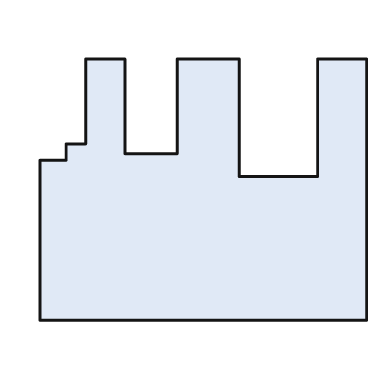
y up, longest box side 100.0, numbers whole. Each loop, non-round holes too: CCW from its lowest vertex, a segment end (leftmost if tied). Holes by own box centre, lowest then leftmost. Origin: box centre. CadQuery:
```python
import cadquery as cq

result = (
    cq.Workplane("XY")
    .moveTo(-50.0, -40.0)
    .lineTo(50.0, -40.0)
    .lineTo(50.0, 40.0)
    .lineTo(35.0, 40.0)
    .lineTo(35.0, 4.0)
    .lineTo(11.0, 4.0)
    .lineTo(11.0, 40.0)
    .lineTo(-8.0, 40.0)
    .lineTo(-8.0, 11.0)
    .lineTo(-24.0, 11.0)
    .lineTo(-24.0, 40.0)
    .lineTo(-36.0, 40.0)
    .lineTo(-36.0, 14.0)
    .lineTo(-42.0, 14.0)
    .lineTo(-42.0, 9.0)
    .lineTo(-50.0, 9.0)
    .close()
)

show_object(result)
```